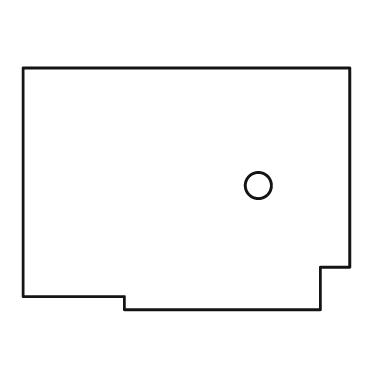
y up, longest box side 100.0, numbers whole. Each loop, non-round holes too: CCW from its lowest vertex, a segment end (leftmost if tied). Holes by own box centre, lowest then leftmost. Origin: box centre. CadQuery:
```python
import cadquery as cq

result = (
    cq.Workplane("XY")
    .moveTo(-19.0, -37.0)
    .lineTo(41.0, -37.0)
    .lineTo(41.0, -24.0)
    .lineTo(50.0, -24.0)
    .lineTo(50.0, 37.0)
    .lineTo(-50.0, 37.0)
    .lineTo(-50.0, -33.0)
    .lineTo(-19.0, -33.0)
    .close()
    .moveTo(22.0, 1.0)
    .circle(4.0)
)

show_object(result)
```